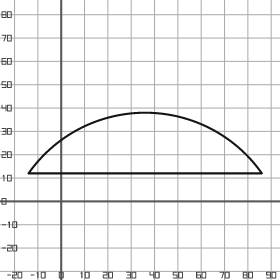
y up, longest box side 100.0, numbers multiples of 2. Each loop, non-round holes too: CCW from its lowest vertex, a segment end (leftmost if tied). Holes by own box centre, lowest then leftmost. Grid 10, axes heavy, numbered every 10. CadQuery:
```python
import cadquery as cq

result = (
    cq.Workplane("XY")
    .moveTo(-14.0, 12.0)
    .lineTo(86.0, 12.0)
    .threePointArc((36.0, 38.0), (-14.0, 12.0))
    .close()
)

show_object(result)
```